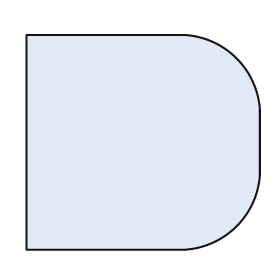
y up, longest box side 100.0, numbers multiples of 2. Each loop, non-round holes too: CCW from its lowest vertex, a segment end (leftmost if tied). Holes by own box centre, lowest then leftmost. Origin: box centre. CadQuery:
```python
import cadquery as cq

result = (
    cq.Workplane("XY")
    .moveTo(-50.0, -46.0)
    .lineTo(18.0, -46.0)
    .threePointArc((40.0, -36.0), (50.0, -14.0))
    .lineTo(50.0, 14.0)
    .threePointArc((40.0, 36.0), (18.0, 46.0))
    .lineTo(-50.0, 46.0)
    .close()
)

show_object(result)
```